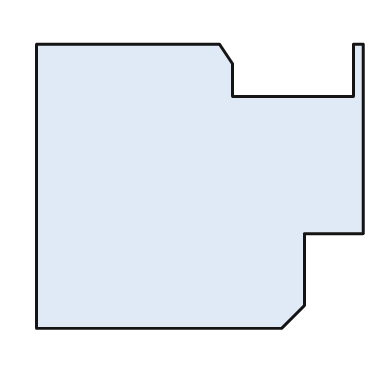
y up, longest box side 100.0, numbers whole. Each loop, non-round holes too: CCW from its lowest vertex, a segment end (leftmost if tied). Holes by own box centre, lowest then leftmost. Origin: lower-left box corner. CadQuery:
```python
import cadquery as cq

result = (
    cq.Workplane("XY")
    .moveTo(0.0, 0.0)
    .lineTo(75.0, 0.0)
    .lineTo(82.0, 7.0)
    .lineTo(82.0, 29.0)
    .lineTo(100.0, 29.0)
    .lineTo(100.0, 87.0)
    .lineTo(97.0, 87.0)
    .lineTo(97.0, 71.0)
    .lineTo(60.0, 71.0)
    .lineTo(60.0, 81.0)
    .lineTo(56.0, 87.0)
    .lineTo(0.0, 87.0)
    .close()
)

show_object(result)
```